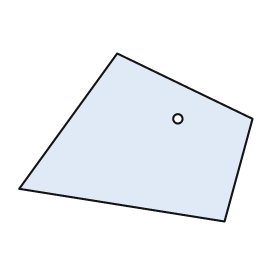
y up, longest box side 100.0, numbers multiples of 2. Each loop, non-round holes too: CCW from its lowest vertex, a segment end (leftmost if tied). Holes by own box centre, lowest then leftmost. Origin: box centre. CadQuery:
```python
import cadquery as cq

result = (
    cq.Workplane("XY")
    .moveTo(38.0, -36.0)
    .lineTo(50.0, 8.0)
    .lineTo(-8.0, 36.0)
    .lineTo(-50.0, -22.0)
    .close()
    .moveTo(18.0, 8.0)
    .circle(2.0)
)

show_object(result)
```